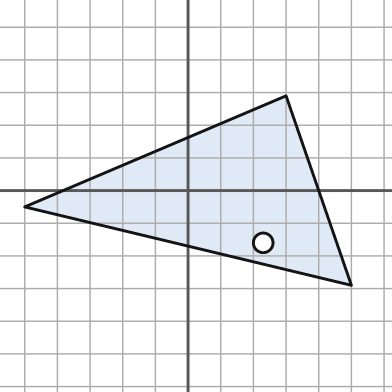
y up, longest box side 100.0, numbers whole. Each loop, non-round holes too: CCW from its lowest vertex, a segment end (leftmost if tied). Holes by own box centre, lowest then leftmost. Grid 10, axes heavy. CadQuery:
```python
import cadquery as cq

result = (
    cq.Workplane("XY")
    .moveTo(50.0, -29.0)
    .lineTo(30.0, 29.0)
    .lineTo(-50.0, -5.0)
    .close()
    .moveTo(23.0, -16.0)
    .circle(3.0)
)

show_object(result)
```